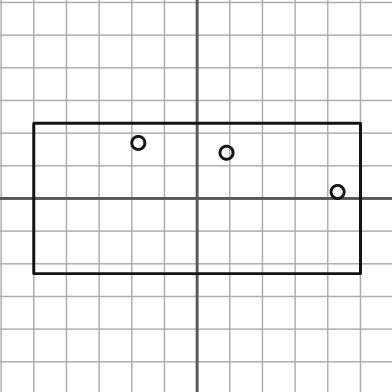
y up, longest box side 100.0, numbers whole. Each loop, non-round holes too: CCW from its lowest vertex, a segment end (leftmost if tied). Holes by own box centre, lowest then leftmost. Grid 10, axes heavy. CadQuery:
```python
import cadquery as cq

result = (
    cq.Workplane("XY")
    .moveTo(-50.0, -23.0)
    .lineTo(50.0, -23.0)
    .lineTo(50.0, 23.0)
    .lineTo(-50.0, 23.0)
    .close()
    .moveTo(43.0, 2.0)
    .circle(2.0)
    .moveTo(9.0, 14.0)
    .circle(2.0)
    .moveTo(-18.0, 17.0)
    .circle(2.0)
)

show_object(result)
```